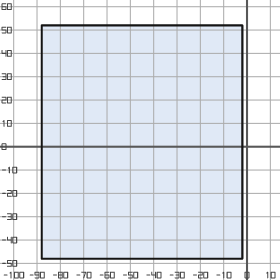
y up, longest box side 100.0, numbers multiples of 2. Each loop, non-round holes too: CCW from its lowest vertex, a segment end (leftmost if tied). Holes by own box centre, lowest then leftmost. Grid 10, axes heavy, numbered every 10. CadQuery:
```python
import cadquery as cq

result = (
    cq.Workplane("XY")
    .moveTo(-88.0, -48.0)
    .lineTo(-2.0, -48.0)
    .lineTo(-2.0, 52.0)
    .lineTo(-88.0, 52.0)
    .close()
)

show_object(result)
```